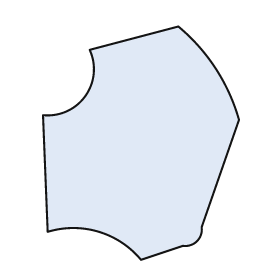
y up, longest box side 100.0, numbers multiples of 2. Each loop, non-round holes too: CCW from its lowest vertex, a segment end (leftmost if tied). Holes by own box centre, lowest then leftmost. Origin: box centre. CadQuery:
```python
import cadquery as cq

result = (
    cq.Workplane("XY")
    .moveTo(0.0, -50.0)
    .lineTo(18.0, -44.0)
    .threePointArc((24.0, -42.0), (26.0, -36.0))
    .lineTo(42.0, 10.0)
    .threePointArc((32.0, 32.0), (16.0, 50.0))
    .lineTo(-22.0, 40.0)
    .threePointArc((-24.0, 20.0), (-42.0, 12.0))
    .lineTo(-40.0, -38.0)
    .threePointArc((-18.0, -38.0), (0.0, -50.0))
    .close()
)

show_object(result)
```